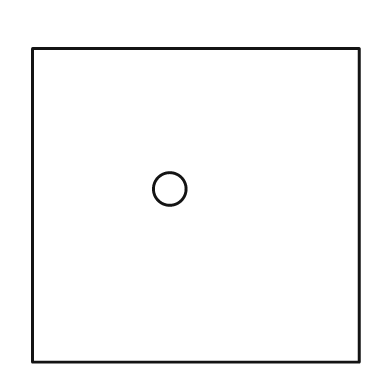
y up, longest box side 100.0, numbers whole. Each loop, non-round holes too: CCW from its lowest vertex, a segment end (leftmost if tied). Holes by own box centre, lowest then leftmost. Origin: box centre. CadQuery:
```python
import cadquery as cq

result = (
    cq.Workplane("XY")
    .moveTo(-50.0, -48.0)
    .lineTo(50.0, -48.0)
    .lineTo(50.0, 48.0)
    .lineTo(-50.0, 48.0)
    .close()
    .moveTo(-8.0, 5.0)
    .circle(5.0)
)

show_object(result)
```